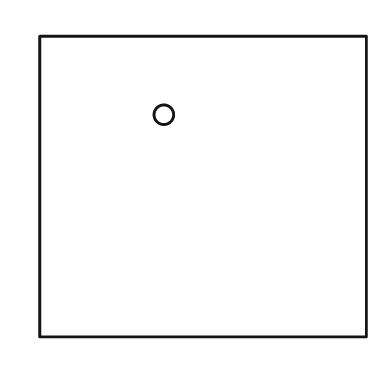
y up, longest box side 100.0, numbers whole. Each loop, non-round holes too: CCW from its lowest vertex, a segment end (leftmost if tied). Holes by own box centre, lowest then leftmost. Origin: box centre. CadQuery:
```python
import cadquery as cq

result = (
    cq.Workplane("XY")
    .moveTo(-50.0, -46.0)
    .lineTo(50.0, -46.0)
    .lineTo(50.0, 46.0)
    .lineTo(-50.0, 46.0)
    .close()
    .moveTo(-12.0, 22.0)
    .circle(3.0)
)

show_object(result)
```